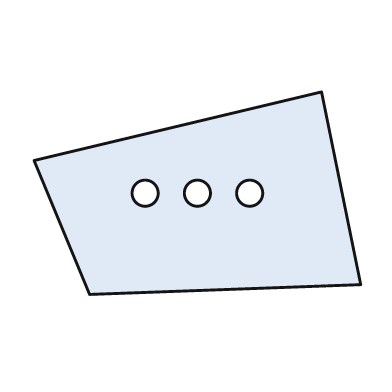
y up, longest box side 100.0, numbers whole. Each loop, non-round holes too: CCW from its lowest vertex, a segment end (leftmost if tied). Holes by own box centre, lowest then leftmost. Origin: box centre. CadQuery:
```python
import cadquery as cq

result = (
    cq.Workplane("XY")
    .moveTo(-33.0, -31.0)
    .lineTo(50.0, -28.0)
    .lineTo(38.0, 31.0)
    .lineTo(-50.0, 10.0)
    .close()
    .moveTo(-16.0, 0.0)
    .circle(4.0)
    .moveTo(0.0, 0.0)
    .circle(4.0)
    .moveTo(16.0, 0.0)
    .circle(4.0)
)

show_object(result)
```